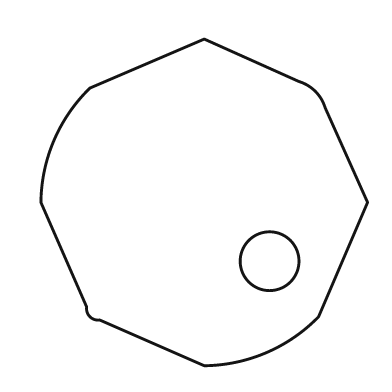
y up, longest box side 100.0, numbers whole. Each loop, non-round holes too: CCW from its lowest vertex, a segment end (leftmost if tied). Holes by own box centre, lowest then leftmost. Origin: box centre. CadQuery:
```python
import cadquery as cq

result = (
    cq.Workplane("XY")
    .moveTo(0.0, -50.0)
    .threePointArc((19.0, -46.0), (35.0, -35.0))
    .lineTo(50.0, 0.0)
    .lineTo(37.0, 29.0)
    .threePointArc((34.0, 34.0), (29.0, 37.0))
    .lineTo(0.0, 50.0)
    .lineTo(-35.0, 35.0)
    .threePointArc((-46.0, 19.0), (-50.0, 0.0))
    .lineTo(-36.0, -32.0)
    .threePointArc((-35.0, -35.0), (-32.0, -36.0))
    .close()
    .moveTo(20.0, -18.0)
    .circle(9.0)
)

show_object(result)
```